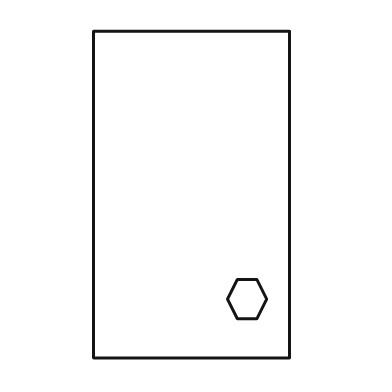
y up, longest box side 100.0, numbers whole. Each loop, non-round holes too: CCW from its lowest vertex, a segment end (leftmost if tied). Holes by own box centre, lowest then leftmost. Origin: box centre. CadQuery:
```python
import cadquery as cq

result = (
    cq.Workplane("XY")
    .moveTo(-30.0, -50.0)
    .lineTo(30.0, -50.0)
    .lineTo(30.0, 50.0)
    .lineTo(-30.0, 50.0)
    .close()
    .moveTo(14.0, -38.0)
    .lineTo(20.0, -38.0)
    .lineTo(23.0, -32.0)
    .lineTo(20.0, -26.0)
    .lineTo(14.0, -26.0)
    .lineTo(11.0, -32.0)
    .close()
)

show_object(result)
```